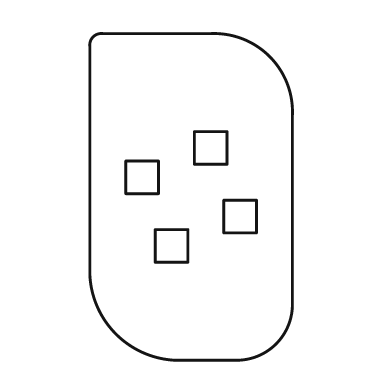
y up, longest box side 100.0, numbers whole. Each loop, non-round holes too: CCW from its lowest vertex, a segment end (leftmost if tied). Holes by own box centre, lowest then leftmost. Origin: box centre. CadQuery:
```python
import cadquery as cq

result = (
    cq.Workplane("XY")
    .moveTo(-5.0, -50.0)
    .lineTo(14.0, -50.0)
    .threePointArc((26.0, -45.0), (31.0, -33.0))
    .lineTo(31.0, 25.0)
    .threePointArc((24.0, 43.0), (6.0, 50.0))
    .lineTo(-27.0, 50.0)
    .threePointArc((-30.0, 49.0), (-31.0, 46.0))
    .lineTo(-31.0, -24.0)
    .threePointArc((-23.0, -42.0), (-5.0, -50.0))
    .close()
    .moveTo(-11.0, -20.0)
    .lineTo(-1.0, -20.0)
    .lineTo(-1.0, -10.0)
    .lineTo(-11.0, -10.0)
    .close()
    .moveTo(10.0, -11.0)
    .lineTo(20.0, -11.0)
    .lineTo(20.0, -1.0)
    .lineTo(10.0, -1.0)
    .close()
    .moveTo(-20.0, 1.0)
    .lineTo(-10.0, 1.0)
    .lineTo(-10.0, 11.0)
    .lineTo(-20.0, 11.0)
    .close()
    .moveTo(1.0, 10.0)
    .lineTo(11.0, 10.0)
    .lineTo(11.0, 20.0)
    .lineTo(1.0, 20.0)
    .close()
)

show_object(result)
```